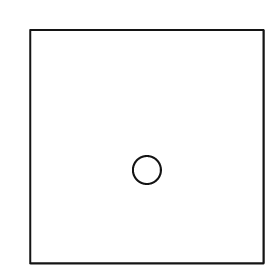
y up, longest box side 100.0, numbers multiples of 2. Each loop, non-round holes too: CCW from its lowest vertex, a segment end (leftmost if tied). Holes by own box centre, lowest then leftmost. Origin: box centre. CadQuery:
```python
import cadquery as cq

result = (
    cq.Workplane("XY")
    .moveTo(-50.0, -50.0)
    .lineTo(50.0, -50.0)
    .lineTo(50.0, 50.0)
    .lineTo(-50.0, 50.0)
    .close()
    .moveTo(0.0, -10.0)
    .circle(6.0)
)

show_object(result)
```